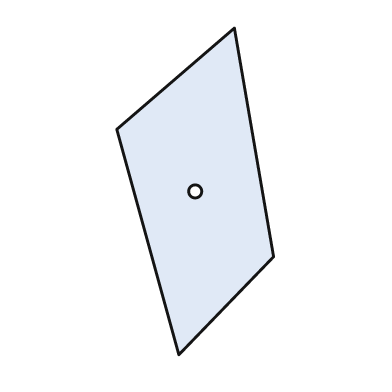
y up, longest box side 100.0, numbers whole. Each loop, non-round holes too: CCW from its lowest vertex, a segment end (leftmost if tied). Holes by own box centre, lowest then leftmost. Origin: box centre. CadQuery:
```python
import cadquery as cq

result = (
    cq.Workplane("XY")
    .moveTo(-5.0, -50.0)
    .lineTo(24.0, -20.0)
    .lineTo(12.0, 50.0)
    .lineTo(-24.0, 19.0)
    .close()
    .moveTo(0.0, 0.0)
    .circle(2.0)
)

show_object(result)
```